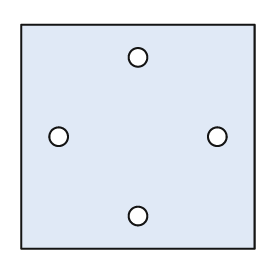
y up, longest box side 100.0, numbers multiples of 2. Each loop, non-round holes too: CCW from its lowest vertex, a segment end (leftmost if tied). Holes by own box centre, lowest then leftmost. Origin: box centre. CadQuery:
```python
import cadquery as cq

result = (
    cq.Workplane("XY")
    .moveTo(-50.0, -48.0)
    .lineTo(50.0, -48.0)
    .lineTo(50.0, 48.0)
    .lineTo(-50.0, 48.0)
    .close()
    .moveTo(0.0, -34.0)
    .circle(4.0)
    .moveTo(-34.0, 0.0)
    .circle(4.0)
    .moveTo(34.0, 0.0)
    .circle(4.0)
    .moveTo(0.0, 34.0)
    .circle(4.0)
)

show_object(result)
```